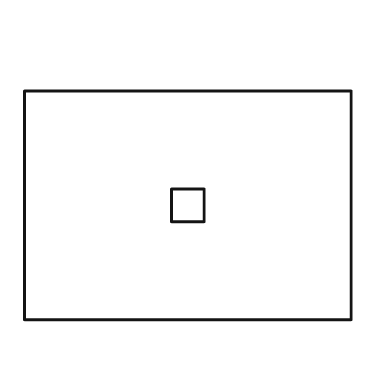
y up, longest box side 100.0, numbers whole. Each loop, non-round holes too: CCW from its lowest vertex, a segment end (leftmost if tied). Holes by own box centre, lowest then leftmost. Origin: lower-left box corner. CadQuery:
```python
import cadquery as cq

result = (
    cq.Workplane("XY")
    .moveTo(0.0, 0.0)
    .lineTo(100.0, 0.0)
    .lineTo(100.0, 70.0)
    .lineTo(0.0, 70.0)
    .close()
    .moveTo(45.0, 30.0)
    .lineTo(55.0, 30.0)
    .lineTo(55.0, 40.0)
    .lineTo(45.0, 40.0)
    .close()
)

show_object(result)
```